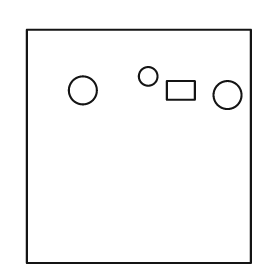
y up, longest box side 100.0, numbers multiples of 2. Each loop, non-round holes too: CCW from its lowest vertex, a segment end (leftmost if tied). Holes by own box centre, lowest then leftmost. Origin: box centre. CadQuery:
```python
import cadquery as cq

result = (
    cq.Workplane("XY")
    .moveTo(-48.0, -50.0)
    .lineTo(48.0, -50.0)
    .lineTo(48.0, 50.0)
    .lineTo(-48.0, 50.0)
    .close()
    .moveTo(38.0, 22.0)
    .circle(6.0)
    .moveTo(-24.0, 24.0)
    .circle(6.0)
    .moveTo(12.0, 20.0)
    .lineTo(24.0, 20.0)
    .lineTo(24.0, 28.0)
    .lineTo(12.0, 28.0)
    .close()
    .moveTo(4.0, 30.0)
    .circle(4.0)
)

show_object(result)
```